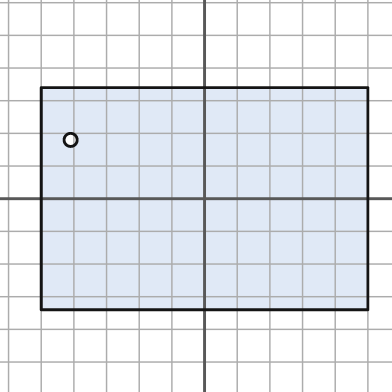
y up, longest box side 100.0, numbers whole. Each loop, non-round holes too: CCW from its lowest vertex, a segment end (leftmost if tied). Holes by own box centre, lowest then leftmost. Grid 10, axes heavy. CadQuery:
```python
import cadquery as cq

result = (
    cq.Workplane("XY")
    .moveTo(-50.0, -34.0)
    .lineTo(50.0, -34.0)
    .lineTo(50.0, 34.0)
    .lineTo(-50.0, 34.0)
    .close()
    .moveTo(-41.0, 18.0)
    .circle(2.0)
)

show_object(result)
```